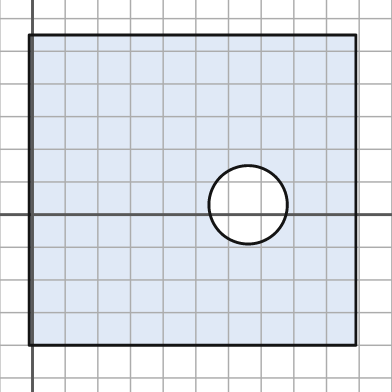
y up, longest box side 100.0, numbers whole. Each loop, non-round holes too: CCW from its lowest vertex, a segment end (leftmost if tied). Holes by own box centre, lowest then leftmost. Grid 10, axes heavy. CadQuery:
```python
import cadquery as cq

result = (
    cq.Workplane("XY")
    .moveTo(-1.0, -40.0)
    .lineTo(99.0, -40.0)
    .lineTo(99.0, 55.0)
    .lineTo(-1.0, 55.0)
    .close()
    .moveTo(66.0, 3.0)
    .circle(12.0)
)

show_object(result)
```